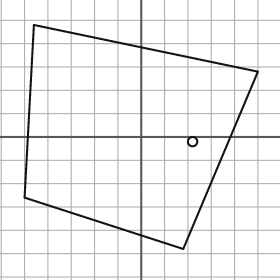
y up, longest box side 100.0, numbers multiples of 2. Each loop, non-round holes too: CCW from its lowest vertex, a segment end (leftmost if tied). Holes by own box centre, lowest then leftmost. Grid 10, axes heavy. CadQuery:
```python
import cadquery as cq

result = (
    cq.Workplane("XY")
    .moveTo(18.0, -48.0)
    .lineTo(50.0, 28.0)
    .lineTo(-46.0, 48.0)
    .lineTo(-50.0, -26.0)
    .close()
    .moveTo(22.0, -2.0)
    .circle(2.0)
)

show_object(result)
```